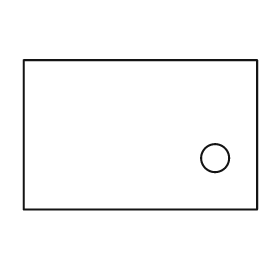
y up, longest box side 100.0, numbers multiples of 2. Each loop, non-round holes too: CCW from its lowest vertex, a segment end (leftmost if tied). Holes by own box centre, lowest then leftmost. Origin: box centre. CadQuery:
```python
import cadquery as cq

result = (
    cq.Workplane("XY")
    .moveTo(-50.0, -32.0)
    .lineTo(50.0, -32.0)
    .lineTo(50.0, 32.0)
    .lineTo(-50.0, 32.0)
    .close()
    .moveTo(32.0, -10.0)
    .circle(6.0)
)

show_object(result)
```